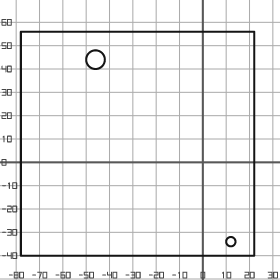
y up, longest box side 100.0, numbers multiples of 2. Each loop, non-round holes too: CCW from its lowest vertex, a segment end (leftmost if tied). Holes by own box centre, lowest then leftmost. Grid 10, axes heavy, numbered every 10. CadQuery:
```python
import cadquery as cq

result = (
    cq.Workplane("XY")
    .moveTo(-78.0, -40.0)
    .lineTo(22.0, -40.0)
    .lineTo(22.0, 56.0)
    .lineTo(-78.0, 56.0)
    .close()
    .moveTo(12.0, -34.0)
    .circle(2.0)
    .moveTo(-46.0, 44.0)
    .circle(4.0)
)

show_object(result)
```